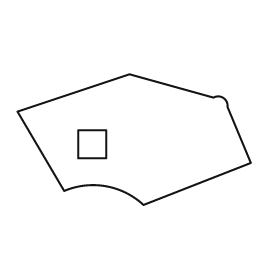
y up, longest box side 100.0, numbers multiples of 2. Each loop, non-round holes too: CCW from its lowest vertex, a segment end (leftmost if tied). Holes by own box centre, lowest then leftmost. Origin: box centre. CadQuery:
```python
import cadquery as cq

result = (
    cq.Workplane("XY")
    .moveTo(4.0, -28.0)
    .lineTo(50.0, -10.0)
    .lineTo(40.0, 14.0)
    .threePointArc((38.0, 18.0), (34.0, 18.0))
    .lineTo(-2.0, 28.0)
    .lineTo(-50.0, 12.0)
    .lineTo(-30.0, -22.0)
    .threePointArc((-12.0, -20.0), (4.0, -28.0))
    .close()
    .moveTo(-24.0, -8.0)
    .lineTo(-12.0, -8.0)
    .lineTo(-12.0, 4.0)
    .lineTo(-24.0, 4.0)
    .close()
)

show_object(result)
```